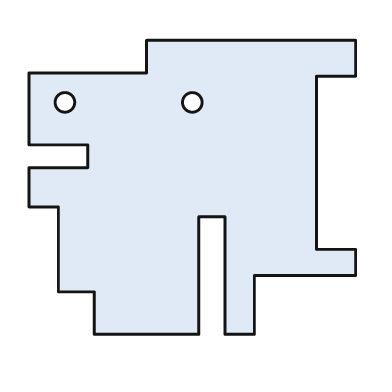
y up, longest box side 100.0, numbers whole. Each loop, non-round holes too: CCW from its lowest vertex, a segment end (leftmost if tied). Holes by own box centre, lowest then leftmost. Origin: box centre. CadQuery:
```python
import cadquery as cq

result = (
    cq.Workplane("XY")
    .moveTo(-30.0, -45.0)
    .lineTo(2.0, -45.0)
    .lineTo(2.0, -9.0)
    .lineTo(10.0, -9.0)
    .lineTo(10.0, -45.0)
    .lineTo(19.0, -45.0)
    .lineTo(19.0, -27.0)
    .lineTo(50.0, -27.0)
    .lineTo(50.0, -19.0)
    .lineTo(38.0, -19.0)
    .lineTo(38.0, 34.0)
    .lineTo(50.0, 34.0)
    .lineTo(50.0, 45.0)
    .lineTo(-14.0, 45.0)
    .lineTo(-14.0, 35.0)
    .lineTo(-50.0, 35.0)
    .lineTo(-50.0, 13.0)
    .lineTo(-32.0, 13.0)
    .lineTo(-32.0, 6.0)
    .lineTo(-50.0, 6.0)
    .lineTo(-50.0, -6.0)
    .lineTo(-41.0, -6.0)
    .lineTo(-41.0, -32.0)
    .lineTo(-30.0, -32.0)
    .close()
    .moveTo(-39.0, 26.0)
    .circle(3.0)
    .moveTo(0.0, 26.0)
    .circle(3.0)
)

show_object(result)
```